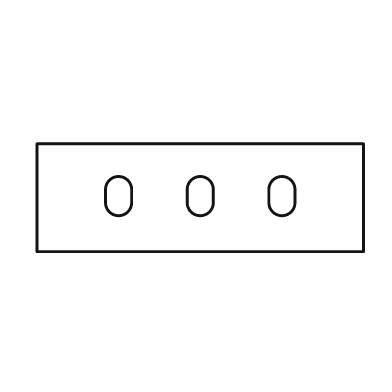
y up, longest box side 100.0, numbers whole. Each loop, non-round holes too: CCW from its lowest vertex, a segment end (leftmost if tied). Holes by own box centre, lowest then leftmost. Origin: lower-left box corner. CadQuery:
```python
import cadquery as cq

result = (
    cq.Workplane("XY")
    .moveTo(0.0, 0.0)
    .lineTo(100.0, 0.0)
    .lineTo(100.0, 33.0)
    .lineTo(0.0, 33.0)
    .close()
    .moveTo(21.0, 15.0)
    .threePointArc((25.0, 11.0), (29.0, 15.0))
    .lineTo(29.0, 19.0)
    .threePointArc((25.0, 23.0), (21.0, 19.0))
    .close()
    .moveTo(46.0, 15.0)
    .threePointArc((50.0, 11.0), (54.0, 15.0))
    .lineTo(54.0, 19.0)
    .threePointArc((50.0, 23.0), (46.0, 19.0))
    .close()
    .moveTo(71.0, 15.0)
    .threePointArc((75.0, 11.0), (79.0, 15.0))
    .lineTo(79.0, 19.0)
    .threePointArc((75.0, 23.0), (71.0, 19.0))
    .close()
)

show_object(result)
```